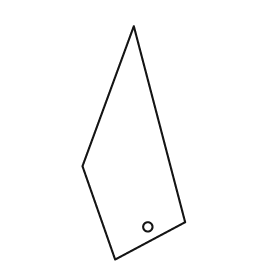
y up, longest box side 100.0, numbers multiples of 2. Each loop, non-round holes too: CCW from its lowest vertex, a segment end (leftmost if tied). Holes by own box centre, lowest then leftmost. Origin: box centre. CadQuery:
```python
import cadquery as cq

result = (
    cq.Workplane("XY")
    .moveTo(-8.0, -50.0)
    .lineTo(22.0, -34.0)
    .lineTo(0.0, 50.0)
    .lineTo(-22.0, -10.0)
    .close()
    .moveTo(6.0, -36.0)
    .circle(2.0)
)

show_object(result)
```